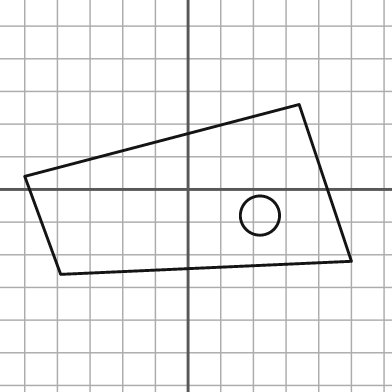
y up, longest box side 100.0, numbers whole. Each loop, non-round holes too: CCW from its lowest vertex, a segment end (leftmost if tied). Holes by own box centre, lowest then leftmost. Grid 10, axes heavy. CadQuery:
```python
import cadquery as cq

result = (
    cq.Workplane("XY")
    .moveTo(-39.0, -26.0)
    .lineTo(50.0, -22.0)
    .lineTo(34.0, 26.0)
    .lineTo(-50.0, 4.0)
    .close()
    .moveTo(22.0, -8.0)
    .circle(6.0)
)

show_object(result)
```